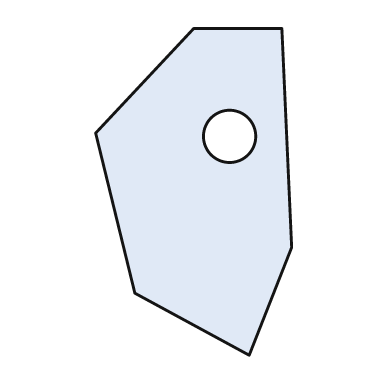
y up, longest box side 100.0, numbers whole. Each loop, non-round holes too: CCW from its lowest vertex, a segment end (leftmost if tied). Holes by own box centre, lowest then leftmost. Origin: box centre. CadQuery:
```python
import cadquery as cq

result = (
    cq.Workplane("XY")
    .moveTo(17.0, -50.0)
    .lineTo(30.0, -17.0)
    .lineTo(27.0, 50.0)
    .lineTo(0.0, 50.0)
    .lineTo(-30.0, 18.0)
    .lineTo(-18.0, -31.0)
    .close()
    .moveTo(11.0, 17.0)
    .circle(8.0)
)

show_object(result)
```